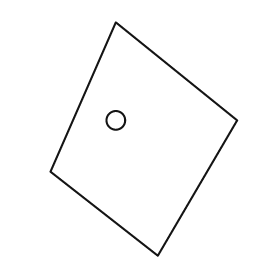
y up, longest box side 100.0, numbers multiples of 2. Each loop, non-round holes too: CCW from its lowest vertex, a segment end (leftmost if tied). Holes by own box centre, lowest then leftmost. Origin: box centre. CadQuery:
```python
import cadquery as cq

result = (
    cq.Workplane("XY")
    .moveTo(6.0, -50.0)
    .lineTo(40.0, 8.0)
    .lineTo(-12.0, 50.0)
    .lineTo(-40.0, -14.0)
    .close()
    .moveTo(-12.0, 8.0)
    .circle(4.0)
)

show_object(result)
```